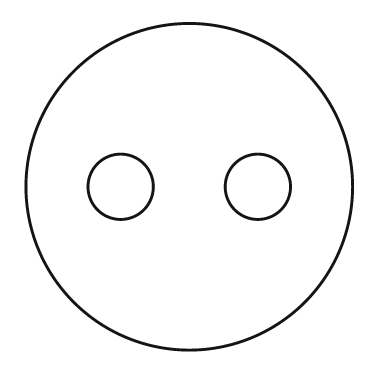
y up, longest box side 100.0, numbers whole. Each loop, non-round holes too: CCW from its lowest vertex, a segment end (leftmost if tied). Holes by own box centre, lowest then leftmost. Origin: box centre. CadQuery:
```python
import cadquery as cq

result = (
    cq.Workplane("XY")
    .moveTo(0.0, 0.0)
    .circle(50.0)
    .moveTo(-21.0, 0.0)
    .circle(10.0)
    .moveTo(21.0, 0.0)
    .circle(10.0)
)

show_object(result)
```